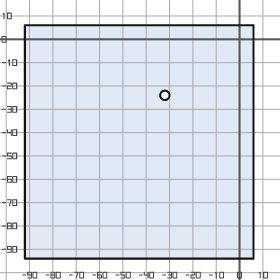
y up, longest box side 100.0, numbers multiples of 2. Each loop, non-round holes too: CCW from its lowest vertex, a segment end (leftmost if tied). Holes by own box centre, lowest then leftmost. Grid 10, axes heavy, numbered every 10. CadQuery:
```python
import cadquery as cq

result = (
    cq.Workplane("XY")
    .moveTo(-92.0, -94.0)
    .lineTo(6.0, -94.0)
    .lineTo(6.0, 6.0)
    .lineTo(-92.0, 6.0)
    .close()
    .moveTo(-32.0, -24.0)
    .circle(2.0)
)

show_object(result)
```